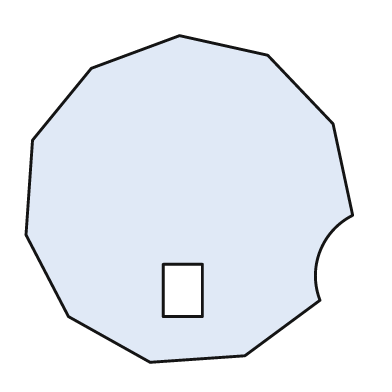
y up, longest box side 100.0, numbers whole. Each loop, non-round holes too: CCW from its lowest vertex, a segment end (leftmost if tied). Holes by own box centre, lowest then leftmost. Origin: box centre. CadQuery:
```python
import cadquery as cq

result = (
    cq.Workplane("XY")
    .moveTo(-12.0, -50.0)
    .lineTo(17.0, -48.0)
    .lineTo(40.0, -31.0)
    .threePointArc((40.0, -16.0), (50.0, -5.0))
    .lineTo(44.0, 23.0)
    .lineTo(24.0, 44.0)
    .lineTo(-3.0, 50.0)
    .lineTo(-30.0, 40.0)
    .lineTo(-48.0, 18.0)
    .lineTo(-50.0, -11.0)
    .lineTo(-37.0, -36.0)
    .close()
    .moveTo(-8.0, -36.0)
    .lineTo(4.0, -36.0)
    .lineTo(4.0, -20.0)
    .lineTo(-8.0, -20.0)
    .close()
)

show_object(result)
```